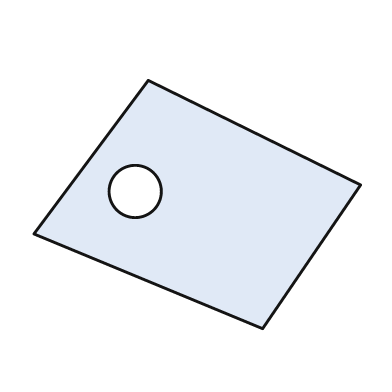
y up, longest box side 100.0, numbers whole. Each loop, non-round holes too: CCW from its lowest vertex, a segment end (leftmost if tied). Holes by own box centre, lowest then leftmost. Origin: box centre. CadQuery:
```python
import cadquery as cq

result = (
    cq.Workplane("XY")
    .moveTo(20.0, -38.0)
    .lineTo(50.0, 6.0)
    .lineTo(-15.0, 38.0)
    .lineTo(-50.0, -9.0)
    .close()
    .moveTo(-19.0, 4.0)
    .circle(8.0)
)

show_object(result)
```